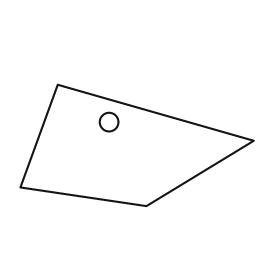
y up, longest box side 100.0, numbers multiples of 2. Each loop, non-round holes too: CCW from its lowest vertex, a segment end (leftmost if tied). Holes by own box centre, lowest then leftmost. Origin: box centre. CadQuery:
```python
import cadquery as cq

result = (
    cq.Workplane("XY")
    .moveTo(4.0, -26.0)
    .lineTo(50.0, 2.0)
    .lineTo(-34.0, 26.0)
    .lineTo(-50.0, -18.0)
    .close()
    .moveTo(-12.0, 10.0)
    .circle(4.0)
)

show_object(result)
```